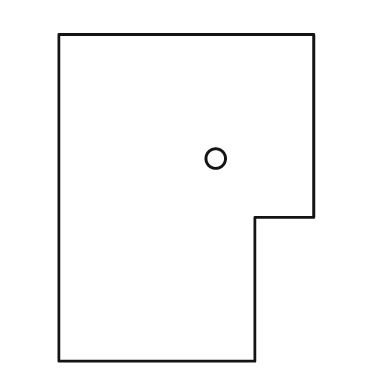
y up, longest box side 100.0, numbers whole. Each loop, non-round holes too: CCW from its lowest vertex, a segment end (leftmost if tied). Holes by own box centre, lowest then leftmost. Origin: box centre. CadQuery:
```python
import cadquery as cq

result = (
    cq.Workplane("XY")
    .moveTo(-39.0, -50.0)
    .lineTo(21.0, -50.0)
    .lineTo(21.0, -6.0)
    .lineTo(39.0, -6.0)
    .lineTo(39.0, 50.0)
    .lineTo(-39.0, 50.0)
    .close()
    .moveTo(9.0, 12.0)
    .circle(3.0)
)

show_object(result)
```